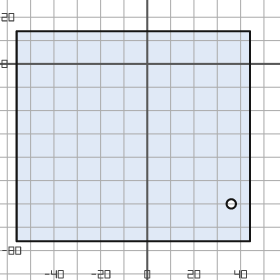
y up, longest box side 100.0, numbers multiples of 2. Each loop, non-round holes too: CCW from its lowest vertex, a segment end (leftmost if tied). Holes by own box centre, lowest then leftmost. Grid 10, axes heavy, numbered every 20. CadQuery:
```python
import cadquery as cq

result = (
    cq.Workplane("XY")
    .moveTo(-56.0, -76.0)
    .lineTo(44.0, -76.0)
    .lineTo(44.0, 14.0)
    .lineTo(-56.0, 14.0)
    .close()
    .moveTo(36.0, -60.0)
    .circle(2.0)
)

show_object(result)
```